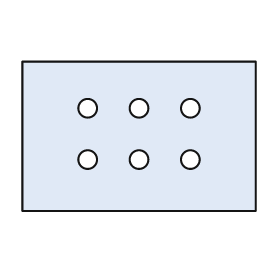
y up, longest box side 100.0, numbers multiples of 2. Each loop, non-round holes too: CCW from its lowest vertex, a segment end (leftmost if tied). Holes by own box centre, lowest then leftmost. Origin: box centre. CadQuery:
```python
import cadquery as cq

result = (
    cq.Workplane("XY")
    .moveTo(-50.0, -32.0)
    .lineTo(50.0, -32.0)
    .lineTo(50.0, 32.0)
    .lineTo(-50.0, 32.0)
    .close()
    .moveTo(-22.0, -10.0)
    .circle(4.0)
    .moveTo(0.0, -10.0)
    .circle(4.0)
    .moveTo(22.0, -10.0)
    .circle(4.0)
    .moveTo(-22.0, 12.0)
    .circle(4.0)
    .moveTo(0.0, 12.0)
    .circle(4.0)
    .moveTo(22.0, 12.0)
    .circle(4.0)
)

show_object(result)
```